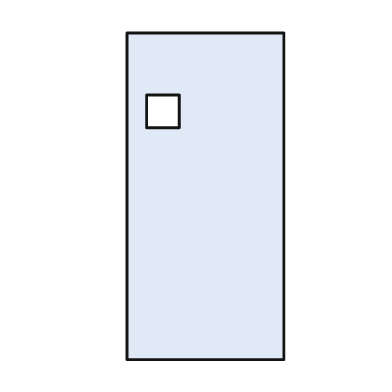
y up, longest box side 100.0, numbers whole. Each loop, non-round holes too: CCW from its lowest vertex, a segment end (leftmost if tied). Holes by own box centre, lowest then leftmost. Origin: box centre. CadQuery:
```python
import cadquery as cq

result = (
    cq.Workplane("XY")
    .moveTo(-24.0, -50.0)
    .lineTo(24.0, -50.0)
    .lineTo(24.0, 50.0)
    .lineTo(-24.0, 50.0)
    .close()
    .moveTo(-18.0, 21.0)
    .lineTo(-8.0, 21.0)
    .lineTo(-8.0, 31.0)
    .lineTo(-18.0, 31.0)
    .close()
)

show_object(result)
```